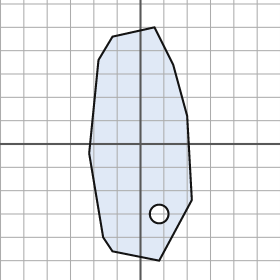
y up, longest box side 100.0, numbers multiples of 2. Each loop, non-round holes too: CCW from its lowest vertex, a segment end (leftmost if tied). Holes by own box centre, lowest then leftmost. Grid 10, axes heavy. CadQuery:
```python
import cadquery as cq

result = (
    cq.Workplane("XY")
    .moveTo(8.0, -50.0)
    .lineTo(22.0, -24.0)
    .lineTo(20.0, 12.0)
    .lineTo(14.0, 34.0)
    .lineTo(6.0, 50.0)
    .lineTo(-12.0, 46.0)
    .lineTo(-18.0, 36.0)
    .lineTo(-22.0, -4.0)
    .lineTo(-16.0, -40.0)
    .lineTo(-12.0, -46.0)
    .close()
    .moveTo(8.0, -30.0)
    .circle(4.0)
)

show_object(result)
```